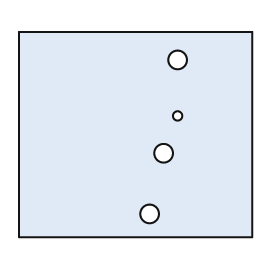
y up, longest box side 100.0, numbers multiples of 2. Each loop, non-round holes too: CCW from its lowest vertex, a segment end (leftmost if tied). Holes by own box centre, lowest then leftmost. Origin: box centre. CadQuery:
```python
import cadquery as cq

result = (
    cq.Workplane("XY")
    .moveTo(-50.0, -44.0)
    .lineTo(50.0, -44.0)
    .lineTo(50.0, 44.0)
    .lineTo(-50.0, 44.0)
    .close()
    .moveTo(6.0, -34.0)
    .circle(4.0)
    .moveTo(12.0, -8.0)
    .circle(4.0)
    .moveTo(18.0, 8.0)
    .circle(2.0)
    .moveTo(18.0, 32.0)
    .circle(4.0)
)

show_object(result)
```